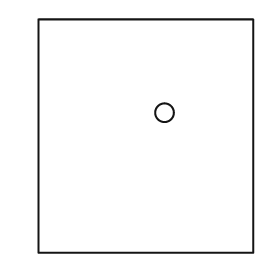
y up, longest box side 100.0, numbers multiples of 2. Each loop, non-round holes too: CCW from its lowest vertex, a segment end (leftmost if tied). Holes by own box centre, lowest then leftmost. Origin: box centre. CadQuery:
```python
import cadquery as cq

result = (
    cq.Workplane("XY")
    .moveTo(-46.0, -50.0)
    .lineTo(46.0, -50.0)
    .lineTo(46.0, 50.0)
    .lineTo(-46.0, 50.0)
    .close()
    .moveTo(8.0, 10.0)
    .circle(4.0)
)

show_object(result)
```